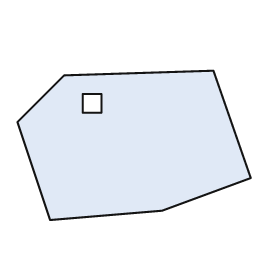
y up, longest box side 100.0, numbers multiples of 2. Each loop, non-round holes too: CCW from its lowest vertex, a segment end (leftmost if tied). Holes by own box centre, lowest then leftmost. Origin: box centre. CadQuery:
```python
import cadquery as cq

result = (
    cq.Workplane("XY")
    .moveTo(-36.0, -32.0)
    .lineTo(12.0, -28.0)
    .lineTo(50.0, -14.0)
    .lineTo(34.0, 32.0)
    .lineTo(-30.0, 30.0)
    .lineTo(-50.0, 10.0)
    .close()
    .moveTo(-22.0, 14.0)
    .lineTo(-14.0, 14.0)
    .lineTo(-14.0, 22.0)
    .lineTo(-22.0, 22.0)
    .close()
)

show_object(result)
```